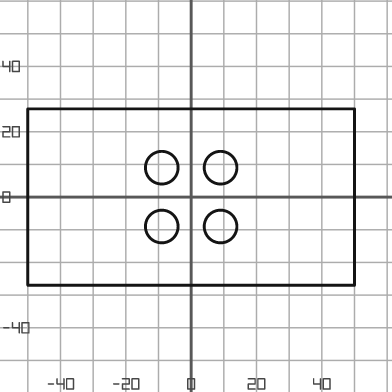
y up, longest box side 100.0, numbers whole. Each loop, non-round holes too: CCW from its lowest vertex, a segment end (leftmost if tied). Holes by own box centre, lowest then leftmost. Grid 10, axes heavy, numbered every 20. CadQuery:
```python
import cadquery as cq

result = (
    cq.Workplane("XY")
    .moveTo(-50.0, -27.0)
    .lineTo(50.0, -27.0)
    .lineTo(50.0, 27.0)
    .lineTo(-50.0, 27.0)
    .close()
    .moveTo(-9.0, -9.0)
    .circle(5.0)
    .moveTo(9.0, -9.0)
    .circle(5.0)
    .moveTo(-9.0, 9.0)
    .circle(5.0)
    .moveTo(9.0, 9.0)
    .circle(5.0)
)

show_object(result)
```